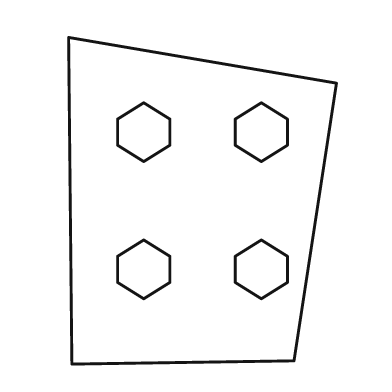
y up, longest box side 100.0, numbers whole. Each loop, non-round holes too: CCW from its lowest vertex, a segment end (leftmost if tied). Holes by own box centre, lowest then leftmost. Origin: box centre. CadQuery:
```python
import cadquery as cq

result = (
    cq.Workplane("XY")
    .moveTo(-40.0, -50.0)
    .lineTo(28.0, -49.0)
    .lineTo(41.0, 36.0)
    .lineTo(-41.0, 50.0)
    .close()
    .moveTo(-18.0, -30.0)
    .lineTo(-10.0, -25.0)
    .lineTo(-10.0, -17.0)
    .lineTo(-18.0, -12.0)
    .lineTo(-26.0, -17.0)
    .lineTo(-26.0, -25.0)
    .close()
    .moveTo(18.0, -30.0)
    .lineTo(26.0, -25.0)
    .lineTo(26.0, -17.0)
    .lineTo(18.0, -12.0)
    .lineTo(10.0, -17.0)
    .lineTo(10.0, -25.0)
    .close()
    .moveTo(-18.0, 12.0)
    .lineTo(-10.0, 17.0)
    .lineTo(-10.0, 25.0)
    .lineTo(-18.0, 30.0)
    .lineTo(-26.0, 25.0)
    .lineTo(-26.0, 17.0)
    .close()
    .moveTo(18.0, 12.0)
    .lineTo(26.0, 17.0)
    .lineTo(26.0, 25.0)
    .lineTo(18.0, 30.0)
    .lineTo(10.0, 25.0)
    .lineTo(10.0, 17.0)
    .close()
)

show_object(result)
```